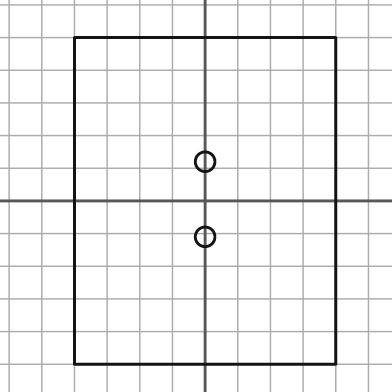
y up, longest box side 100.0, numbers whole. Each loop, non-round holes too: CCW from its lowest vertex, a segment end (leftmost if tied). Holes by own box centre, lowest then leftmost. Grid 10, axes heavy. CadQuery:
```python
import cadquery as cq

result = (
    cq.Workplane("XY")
    .moveTo(-40.0, -50.0)
    .lineTo(40.0, -50.0)
    .lineTo(40.0, 50.0)
    .lineTo(-40.0, 50.0)
    .close()
    .moveTo(0.0, -11.0)
    .circle(3.0)
    .moveTo(0.0, 12.0)
    .circle(3.0)
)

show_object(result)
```